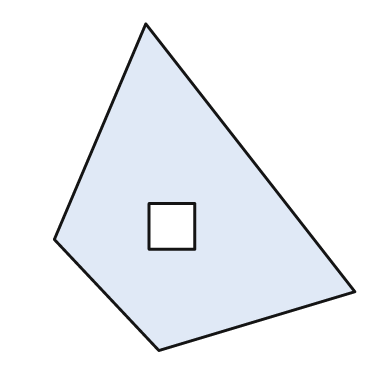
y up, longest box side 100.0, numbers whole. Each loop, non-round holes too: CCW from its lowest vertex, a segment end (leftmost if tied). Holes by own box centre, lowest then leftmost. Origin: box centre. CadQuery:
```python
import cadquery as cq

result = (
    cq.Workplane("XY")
    .moveTo(-14.0, -50.0)
    .lineTo(46.0, -32.0)
    .lineTo(-18.0, 50.0)
    .lineTo(-46.0, -16.0)
    .close()
    .moveTo(-17.0, -19.0)
    .lineTo(-3.0, -19.0)
    .lineTo(-3.0, -5.0)
    .lineTo(-17.0, -5.0)
    .close()
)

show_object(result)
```